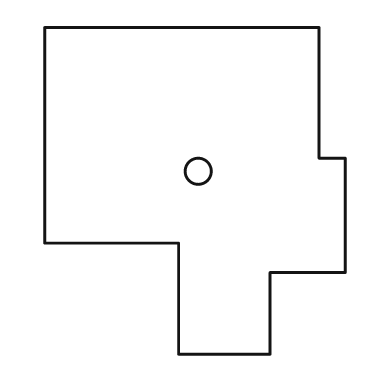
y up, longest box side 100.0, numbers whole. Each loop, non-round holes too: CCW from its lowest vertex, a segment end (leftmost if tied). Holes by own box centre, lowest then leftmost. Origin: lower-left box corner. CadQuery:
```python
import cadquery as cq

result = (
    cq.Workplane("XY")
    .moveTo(41.0, 0.0)
    .lineTo(69.0, 0.0)
    .lineTo(69.0, 25.0)
    .lineTo(92.0, 25.0)
    .lineTo(92.0, 60.0)
    .lineTo(84.0, 60.0)
    .lineTo(84.0, 100.0)
    .lineTo(0.0, 100.0)
    .lineTo(0.0, 34.0)
    .lineTo(41.0, 34.0)
    .close()
    .moveTo(47.0, 56.0)
    .circle(4.0)
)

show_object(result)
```